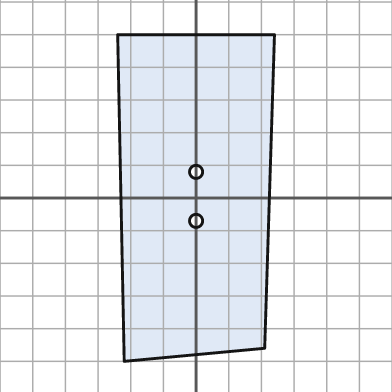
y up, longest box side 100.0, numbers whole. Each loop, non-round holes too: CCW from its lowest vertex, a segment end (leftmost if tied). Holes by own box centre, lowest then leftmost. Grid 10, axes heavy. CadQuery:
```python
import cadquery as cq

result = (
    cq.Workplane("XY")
    .moveTo(-22.0, -50.0)
    .lineTo(21.0, -46.0)
    .lineTo(24.0, 50.0)
    .lineTo(-24.0, 50.0)
    .close()
    .moveTo(0.0, -7.0)
    .circle(2.0)
    .moveTo(0.0, 8.0)
    .circle(2.0)
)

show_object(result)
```